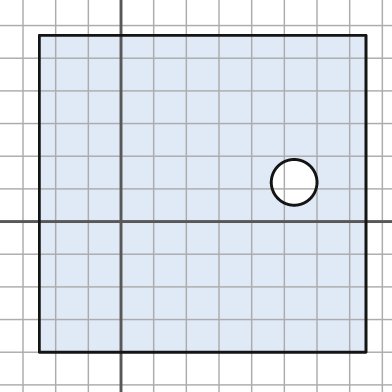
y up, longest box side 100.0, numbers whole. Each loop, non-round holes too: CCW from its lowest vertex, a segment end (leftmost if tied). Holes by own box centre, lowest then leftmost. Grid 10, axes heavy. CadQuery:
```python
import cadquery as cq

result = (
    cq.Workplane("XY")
    .moveTo(-25.0, -40.0)
    .lineTo(75.0, -40.0)
    .lineTo(75.0, 57.0)
    .lineTo(-25.0, 57.0)
    .close()
    .moveTo(53.0, 12.0)
    .circle(7.0)
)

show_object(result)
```